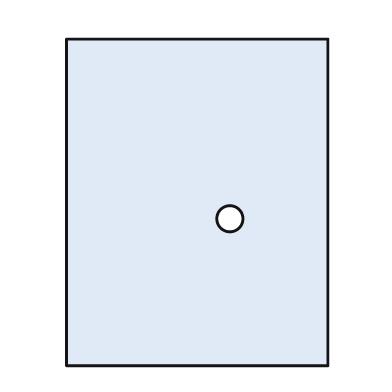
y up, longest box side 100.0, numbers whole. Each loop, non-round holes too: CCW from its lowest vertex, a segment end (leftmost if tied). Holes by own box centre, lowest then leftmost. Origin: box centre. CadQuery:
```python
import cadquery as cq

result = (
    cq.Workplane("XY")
    .moveTo(-40.0, -50.0)
    .lineTo(40.0, -50.0)
    .lineTo(40.0, 50.0)
    .lineTo(-40.0, 50.0)
    .close()
    .moveTo(10.0, -5.0)
    .circle(4.0)
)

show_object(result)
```